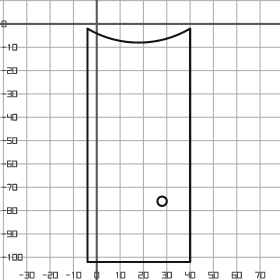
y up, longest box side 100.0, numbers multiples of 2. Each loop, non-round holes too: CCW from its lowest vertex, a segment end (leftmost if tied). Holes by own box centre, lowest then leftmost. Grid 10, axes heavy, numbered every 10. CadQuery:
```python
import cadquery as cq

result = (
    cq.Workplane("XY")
    .moveTo(-4.0, -102.0)
    .lineTo(40.0, -102.0)
    .lineTo(40.0, -2.0)
    .threePointArc((18.0, -8.0), (-4.0, -2.0))
    .close()
    .moveTo(28.0, -76.0)
    .circle(2.0)
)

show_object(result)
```